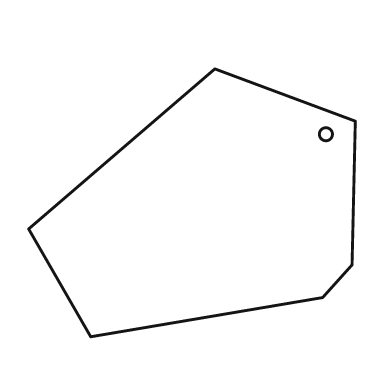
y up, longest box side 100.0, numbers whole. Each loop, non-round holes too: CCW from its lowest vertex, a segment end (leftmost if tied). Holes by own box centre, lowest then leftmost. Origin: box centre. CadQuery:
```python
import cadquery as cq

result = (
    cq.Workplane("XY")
    .moveTo(-31.0, -41.0)
    .lineTo(40.0, -29.0)
    .lineTo(49.0, -19.0)
    .lineTo(50.0, 25.0)
    .lineTo(7.0, 41.0)
    .lineTo(-50.0, -8.0)
    .close()
    .moveTo(41.0, 21.0)
    .circle(2.0)
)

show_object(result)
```